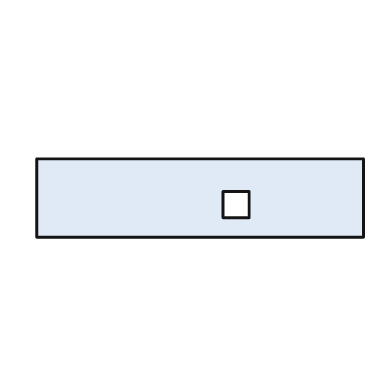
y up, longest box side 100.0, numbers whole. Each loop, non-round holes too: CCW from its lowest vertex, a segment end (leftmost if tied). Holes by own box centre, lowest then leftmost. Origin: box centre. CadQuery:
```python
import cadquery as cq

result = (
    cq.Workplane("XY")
    .moveTo(-50.0, -12.0)
    .lineTo(50.0, -12.0)
    .lineTo(50.0, 12.0)
    .lineTo(-50.0, 12.0)
    .close()
    .moveTo(7.0, -6.0)
    .lineTo(15.0, -6.0)
    .lineTo(15.0, 2.0)
    .lineTo(7.0, 2.0)
    .close()
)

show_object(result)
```